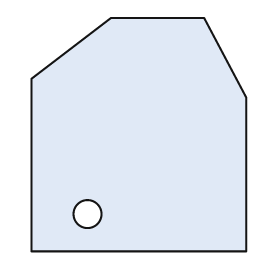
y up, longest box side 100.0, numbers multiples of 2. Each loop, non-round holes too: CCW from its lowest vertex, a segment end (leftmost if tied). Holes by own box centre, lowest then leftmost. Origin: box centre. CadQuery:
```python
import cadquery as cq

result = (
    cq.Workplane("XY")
    .moveTo(-46.0, -50.0)
    .lineTo(46.0, -50.0)
    .lineTo(46.0, 16.0)
    .lineTo(28.0, 50.0)
    .lineTo(-12.0, 50.0)
    .lineTo(-46.0, 24.0)
    .close()
    .moveTo(-22.0, -34.0)
    .circle(6.0)
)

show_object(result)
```